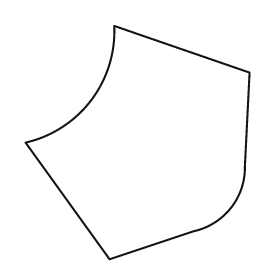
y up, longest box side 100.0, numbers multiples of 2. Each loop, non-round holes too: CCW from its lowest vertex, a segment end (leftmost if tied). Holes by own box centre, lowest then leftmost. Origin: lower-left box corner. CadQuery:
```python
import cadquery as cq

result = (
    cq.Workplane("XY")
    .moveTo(36.0, 0.0)
    .lineTo(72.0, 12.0)
    .threePointArc((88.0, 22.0), (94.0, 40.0))
    .lineTo(96.0, 80.0)
    .lineTo(38.0, 100.0)
    .threePointArc((28.0, 68.0), (0.0, 50.0))
    .close()
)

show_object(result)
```